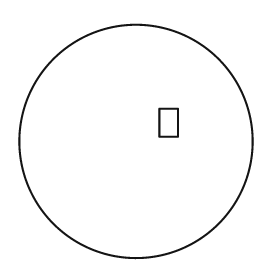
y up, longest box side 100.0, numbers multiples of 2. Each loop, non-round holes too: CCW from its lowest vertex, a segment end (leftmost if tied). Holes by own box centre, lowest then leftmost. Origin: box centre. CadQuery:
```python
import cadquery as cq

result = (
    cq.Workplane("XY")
    .moveTo(0.0, 0.0)
    .circle(50.0)
    .moveTo(10.0, 2.0)
    .lineTo(18.0, 2.0)
    .lineTo(18.0, 14.0)
    .lineTo(10.0, 14.0)
    .close()
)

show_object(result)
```